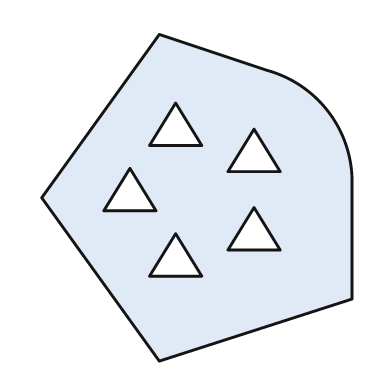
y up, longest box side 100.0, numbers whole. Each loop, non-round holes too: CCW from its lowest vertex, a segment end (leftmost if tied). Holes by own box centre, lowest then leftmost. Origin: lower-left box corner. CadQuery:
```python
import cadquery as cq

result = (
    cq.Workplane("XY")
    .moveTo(36.0, 0.0)
    .lineTo(95.0, 19.0)
    .lineTo(95.0, 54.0)
    .threePointArc((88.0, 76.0), (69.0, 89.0))
    .lineTo(36.0, 100.0)
    .lineTo(0.0, 50.0)
    .close()
    .moveTo(33.0, 26.0)
    .lineTo(49.0, 26.0)
    .lineTo(41.0, 39.0)
    .close()
    .moveTo(57.0, 34.0)
    .lineTo(73.0, 34.0)
    .lineTo(65.0, 47.0)
    .close()
    .moveTo(19.0, 46.0)
    .lineTo(35.0, 46.0)
    .lineTo(27.0, 59.0)
    .close()
    .moveTo(57.0, 58.0)
    .lineTo(73.0, 58.0)
    .lineTo(65.0, 71.0)
    .close()
    .moveTo(33.0, 66.0)
    .lineTo(49.0, 66.0)
    .lineTo(41.0, 79.0)
    .close()
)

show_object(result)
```